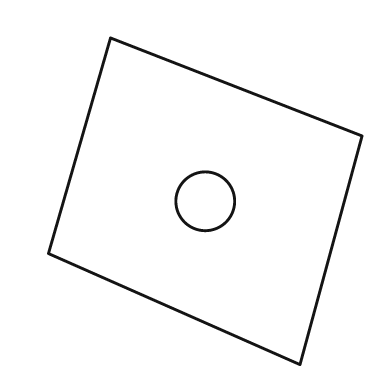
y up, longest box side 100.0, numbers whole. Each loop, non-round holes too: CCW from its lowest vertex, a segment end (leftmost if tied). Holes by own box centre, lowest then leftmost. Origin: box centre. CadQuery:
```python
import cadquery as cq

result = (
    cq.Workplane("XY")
    .moveTo(29.0, -50.0)
    .lineTo(48.0, 20.0)
    .lineTo(-29.0, 50.0)
    .lineTo(-48.0, -16.0)
    .close()
    .moveTo(0.0, 0.0)
    .circle(9.0)
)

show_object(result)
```